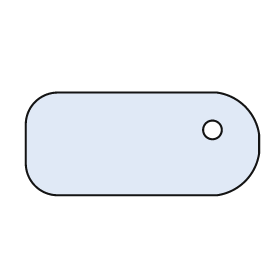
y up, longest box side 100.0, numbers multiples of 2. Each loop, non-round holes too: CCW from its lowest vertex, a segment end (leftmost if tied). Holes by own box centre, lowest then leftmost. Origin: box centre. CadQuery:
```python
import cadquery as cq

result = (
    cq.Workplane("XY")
    .moveTo(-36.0, -22.0)
    .lineTo(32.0, -22.0)
    .threePointArc((44.0, -16.0), (50.0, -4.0))
    .lineTo(50.0, 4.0)
    .threePointArc((44.0, 16.0), (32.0, 22.0))
    .lineTo(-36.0, 22.0)
    .threePointArc((-46.0, 18.0), (-50.0, 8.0))
    .lineTo(-50.0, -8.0)
    .threePointArc((-46.0, -18.0), (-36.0, -22.0))
    .close()
    .moveTo(30.0, 6.0)
    .circle(4.0)
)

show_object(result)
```